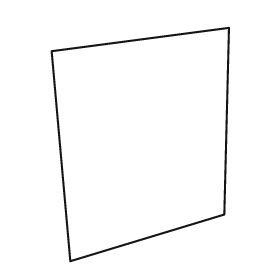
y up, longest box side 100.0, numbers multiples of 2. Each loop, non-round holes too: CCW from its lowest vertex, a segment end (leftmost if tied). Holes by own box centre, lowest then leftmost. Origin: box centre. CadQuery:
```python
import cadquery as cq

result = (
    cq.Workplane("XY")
    .moveTo(-30.0, -50.0)
    .lineTo(36.0, -30.0)
    .lineTo(38.0, 50.0)
    .lineTo(-38.0, 40.0)
    .close()
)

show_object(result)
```